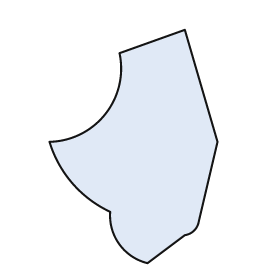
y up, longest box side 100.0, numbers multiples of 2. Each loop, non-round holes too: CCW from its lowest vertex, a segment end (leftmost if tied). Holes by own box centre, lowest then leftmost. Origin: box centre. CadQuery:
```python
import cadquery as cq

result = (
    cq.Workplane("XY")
    .moveTo(6.0, -50.0)
    .lineTo(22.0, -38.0)
    .threePointArc((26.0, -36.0), (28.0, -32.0))
    .lineTo(36.0, 2.0)
    .lineTo(22.0, 50.0)
    .lineTo(-6.0, 40.0)
    .threePointArc((-12.0, 14.0), (-36.0, 2.0))
    .threePointArc((-26.0, -16.0), (-10.0, -28.0))
    .threePointArc((-6.0, -42.0), (6.0, -50.0))
    .close()
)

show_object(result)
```